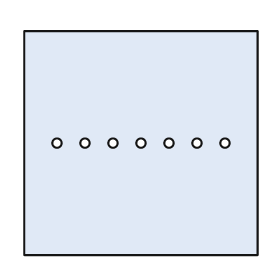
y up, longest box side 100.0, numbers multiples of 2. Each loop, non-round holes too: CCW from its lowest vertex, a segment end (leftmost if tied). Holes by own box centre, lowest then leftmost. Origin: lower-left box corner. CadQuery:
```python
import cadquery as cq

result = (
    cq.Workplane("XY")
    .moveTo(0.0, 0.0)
    .lineTo(100.0, 0.0)
    .lineTo(100.0, 96.0)
    .lineTo(0.0, 96.0)
    .close()
    .moveTo(14.0, 48.0)
    .circle(2.0)
    .moveTo(26.0, 48.0)
    .circle(2.0)
    .moveTo(38.0, 48.0)
    .circle(2.0)
    .moveTo(50.0, 48.0)
    .circle(2.0)
    .moveTo(62.0, 48.0)
    .circle(2.0)
    .moveTo(74.0, 48.0)
    .circle(2.0)
    .moveTo(86.0, 48.0)
    .circle(2.0)
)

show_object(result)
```